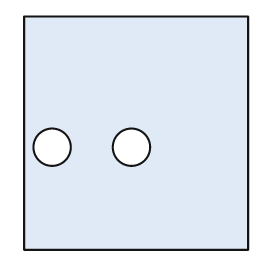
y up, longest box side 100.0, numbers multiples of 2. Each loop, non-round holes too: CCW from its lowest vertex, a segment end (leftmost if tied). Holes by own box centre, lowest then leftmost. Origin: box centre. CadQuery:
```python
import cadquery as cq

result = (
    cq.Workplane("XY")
    .moveTo(-48.0, -50.0)
    .lineTo(48.0, -50.0)
    .lineTo(48.0, 50.0)
    .lineTo(-48.0, 50.0)
    .close()
    .moveTo(-36.0, -6.0)
    .circle(8.0)
    .moveTo(-2.0, -6.0)
    .circle(8.0)
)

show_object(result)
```